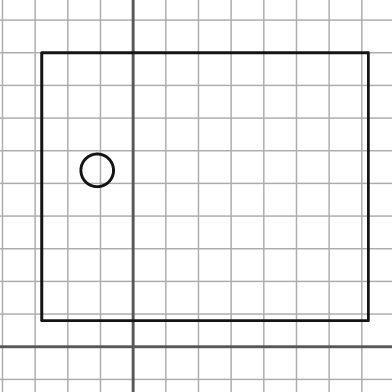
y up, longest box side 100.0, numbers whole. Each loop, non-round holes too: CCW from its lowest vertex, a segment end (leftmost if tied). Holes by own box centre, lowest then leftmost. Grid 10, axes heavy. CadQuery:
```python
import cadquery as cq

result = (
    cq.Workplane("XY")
    .moveTo(-28.0, 8.0)
    .lineTo(72.0, 8.0)
    .lineTo(72.0, 90.0)
    .lineTo(-28.0, 90.0)
    .close()
    .moveTo(-11.0, 54.0)
    .circle(5.0)
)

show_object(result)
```